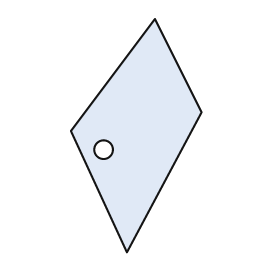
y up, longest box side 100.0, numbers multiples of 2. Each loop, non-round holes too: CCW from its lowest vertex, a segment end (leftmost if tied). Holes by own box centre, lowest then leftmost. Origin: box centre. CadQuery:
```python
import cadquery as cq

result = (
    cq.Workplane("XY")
    .moveTo(-4.0, -50.0)
    .lineTo(28.0, 10.0)
    .lineTo(8.0, 50.0)
    .lineTo(-28.0, 2.0)
    .close()
    .moveTo(-14.0, -6.0)
    .circle(4.0)
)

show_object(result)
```